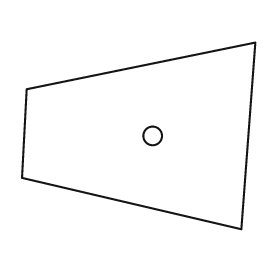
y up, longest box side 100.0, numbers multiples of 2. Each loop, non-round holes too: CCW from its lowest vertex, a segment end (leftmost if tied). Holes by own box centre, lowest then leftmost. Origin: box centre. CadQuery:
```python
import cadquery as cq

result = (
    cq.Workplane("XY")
    .moveTo(44.0, -40.0)
    .lineTo(50.0, 40.0)
    .lineTo(-48.0, 20.0)
    .lineTo(-50.0, -18.0)
    .close()
    .moveTo(6.0, 0.0)
    .circle(4.0)
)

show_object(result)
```